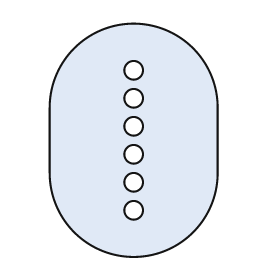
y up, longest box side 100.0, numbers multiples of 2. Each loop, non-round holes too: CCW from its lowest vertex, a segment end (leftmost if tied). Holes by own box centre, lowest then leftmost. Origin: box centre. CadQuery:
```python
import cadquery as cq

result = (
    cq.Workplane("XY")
    .moveTo(-36.0, -14.0)
    .threePointArc((0.0, -50.0), (36.0, -14.0))
    .lineTo(36.0, 14.0)
    .threePointArc((0.0, 50.0), (-36.0, 14.0))
    .close()
    .moveTo(0.0, -30.0)
    .circle(4.0)
    .moveTo(0.0, -18.0)
    .circle(4.0)
    .moveTo(0.0, -6.0)
    .circle(4.0)
    .moveTo(0.0, 6.0)
    .circle(4.0)
    .moveTo(0.0, 18.0)
    .circle(4.0)
    .moveTo(0.0, 30.0)
    .circle(4.0)
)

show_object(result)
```